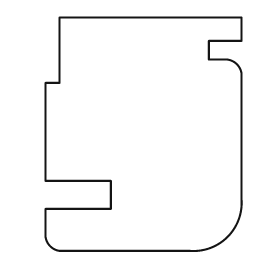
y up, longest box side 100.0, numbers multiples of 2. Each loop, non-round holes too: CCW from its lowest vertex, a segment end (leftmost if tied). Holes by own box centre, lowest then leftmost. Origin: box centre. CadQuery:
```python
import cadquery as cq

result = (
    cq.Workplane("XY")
    .moveTo(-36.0, -50.0)
    .lineTo(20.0, -50.0)
    .threePointArc((36.0, -44.0), (42.0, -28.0))
    .lineTo(42.0, 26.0)
    .threePointArc((40.0, 30.0), (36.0, 32.0))
    .lineTo(28.0, 32.0)
    .lineTo(28.0, 40.0)
    .lineTo(42.0, 40.0)
    .lineTo(42.0, 50.0)
    .lineTo(-36.0, 50.0)
    .lineTo(-36.0, 22.0)
    .lineTo(-42.0, 22.0)
    .lineTo(-42.0, -20.0)
    .lineTo(-14.0, -20.0)
    .lineTo(-14.0, -32.0)
    .lineTo(-42.0, -32.0)
    .lineTo(-42.0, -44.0)
    .threePointArc((-40.0, -48.0), (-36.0, -50.0))
    .close()
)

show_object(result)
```